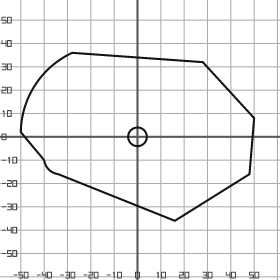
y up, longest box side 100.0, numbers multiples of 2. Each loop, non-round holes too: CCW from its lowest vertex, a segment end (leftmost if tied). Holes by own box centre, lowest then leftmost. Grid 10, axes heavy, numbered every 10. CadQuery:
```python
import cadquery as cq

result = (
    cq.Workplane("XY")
    .moveTo(16.0, -36.0)
    .lineTo(48.0, -16.0)
    .lineTo(50.0, 8.0)
    .lineTo(28.0, 32.0)
    .lineTo(-28.0, 36.0)
    .threePointArc((-44.0, 22.0), (-50.0, 2.0))
    .lineTo(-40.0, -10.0)
    .threePointArc((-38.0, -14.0), (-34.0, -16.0))
    .close()
    .moveTo(0.0, 0.0)
    .circle(4.0)
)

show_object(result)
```